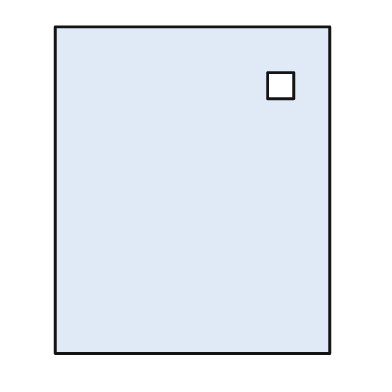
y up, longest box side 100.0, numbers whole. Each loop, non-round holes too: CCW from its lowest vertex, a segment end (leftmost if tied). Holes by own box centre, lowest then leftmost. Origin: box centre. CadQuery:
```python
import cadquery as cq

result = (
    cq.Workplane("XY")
    .moveTo(-42.0, -50.0)
    .lineTo(42.0, -50.0)
    .lineTo(42.0, 50.0)
    .lineTo(-42.0, 50.0)
    .close()
    .moveTo(23.0, 28.0)
    .lineTo(31.0, 28.0)
    .lineTo(31.0, 36.0)
    .lineTo(23.0, 36.0)
    .close()
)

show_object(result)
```